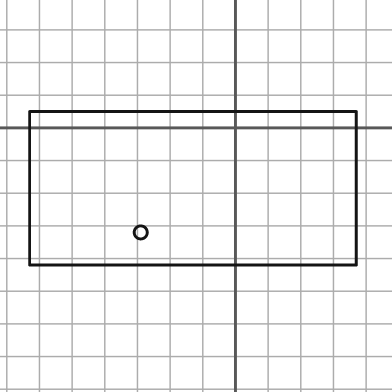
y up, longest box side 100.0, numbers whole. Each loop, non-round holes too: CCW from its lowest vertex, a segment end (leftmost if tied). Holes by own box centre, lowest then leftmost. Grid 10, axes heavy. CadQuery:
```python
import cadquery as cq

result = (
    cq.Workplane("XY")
    .moveTo(-63.0, -42.0)
    .lineTo(37.0, -42.0)
    .lineTo(37.0, 5.0)
    .lineTo(-63.0, 5.0)
    .close()
    .moveTo(-29.0, -32.0)
    .circle(2.0)
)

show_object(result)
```